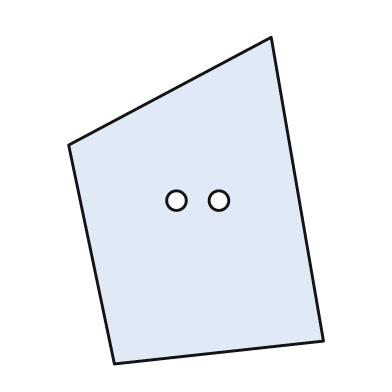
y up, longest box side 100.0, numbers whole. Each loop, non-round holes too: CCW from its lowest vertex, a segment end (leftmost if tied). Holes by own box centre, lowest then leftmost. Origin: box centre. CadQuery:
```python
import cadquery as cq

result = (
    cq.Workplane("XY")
    .moveTo(-25.0, -50.0)
    .lineTo(39.0, -43.0)
    .lineTo(23.0, 50.0)
    .lineTo(-39.0, 17.0)
    .close()
    .moveTo(-6.0, 0.0)
    .circle(3.0)
    .moveTo(7.0, 0.0)
    .circle(3.0)
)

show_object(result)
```